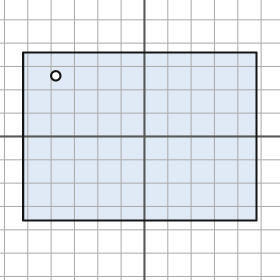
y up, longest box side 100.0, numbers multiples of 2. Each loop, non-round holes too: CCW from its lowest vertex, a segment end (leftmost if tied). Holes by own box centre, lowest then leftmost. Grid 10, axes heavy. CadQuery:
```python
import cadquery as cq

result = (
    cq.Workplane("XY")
    .moveTo(-52.0, -36.0)
    .lineTo(48.0, -36.0)
    .lineTo(48.0, 36.0)
    .lineTo(-52.0, 36.0)
    .close()
    .moveTo(-38.0, 26.0)
    .circle(2.0)
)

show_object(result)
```